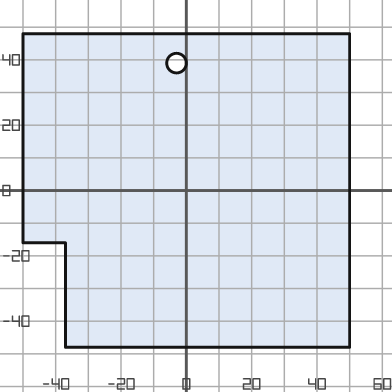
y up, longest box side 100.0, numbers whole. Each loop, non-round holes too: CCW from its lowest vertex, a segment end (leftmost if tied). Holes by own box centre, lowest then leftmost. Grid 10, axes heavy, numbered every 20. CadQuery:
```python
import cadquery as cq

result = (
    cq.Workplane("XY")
    .moveTo(-37.0, -48.0)
    .lineTo(50.0, -48.0)
    .lineTo(50.0, 48.0)
    .lineTo(-50.0, 48.0)
    .lineTo(-50.0, -16.0)
    .lineTo(-37.0, -16.0)
    .close()
    .moveTo(-3.0, 39.0)
    .circle(3.0)
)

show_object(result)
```